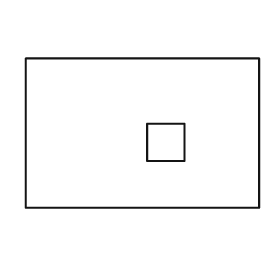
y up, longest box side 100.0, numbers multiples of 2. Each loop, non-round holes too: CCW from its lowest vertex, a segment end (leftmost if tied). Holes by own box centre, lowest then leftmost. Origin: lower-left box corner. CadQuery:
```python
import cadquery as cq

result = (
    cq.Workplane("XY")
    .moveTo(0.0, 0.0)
    .lineTo(100.0, 0.0)
    .lineTo(100.0, 64.0)
    .lineTo(0.0, 64.0)
    .close()
    .moveTo(52.0, 20.0)
    .lineTo(68.0, 20.0)
    .lineTo(68.0, 36.0)
    .lineTo(52.0, 36.0)
    .close()
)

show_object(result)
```